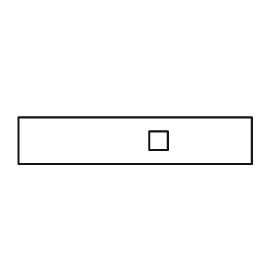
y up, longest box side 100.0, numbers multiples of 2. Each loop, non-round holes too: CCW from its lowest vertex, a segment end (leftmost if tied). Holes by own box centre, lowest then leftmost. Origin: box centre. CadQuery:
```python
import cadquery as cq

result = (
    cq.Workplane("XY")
    .moveTo(-50.0, -10.0)
    .lineTo(50.0, -10.0)
    .lineTo(50.0, 10.0)
    .lineTo(-50.0, 10.0)
    .close()
    .moveTo(6.0, -4.0)
    .lineTo(14.0, -4.0)
    .lineTo(14.0, 4.0)
    .lineTo(6.0, 4.0)
    .close()
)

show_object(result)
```